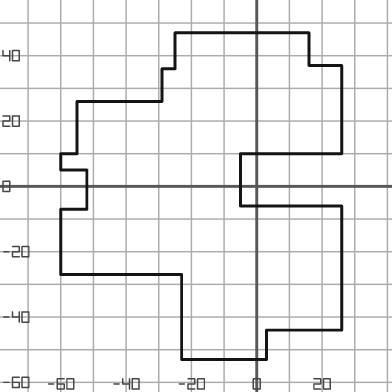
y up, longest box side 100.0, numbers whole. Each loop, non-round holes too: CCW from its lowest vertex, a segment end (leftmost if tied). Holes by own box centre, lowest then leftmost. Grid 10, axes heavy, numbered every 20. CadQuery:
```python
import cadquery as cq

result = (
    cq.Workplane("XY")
    .moveTo(-23.0, -53.0)
    .lineTo(3.0, -53.0)
    .lineTo(3.0, -44.0)
    .lineTo(26.0, -44.0)
    .lineTo(26.0, -6.0)
    .lineTo(-5.0, -6.0)
    .lineTo(-5.0, 10.0)
    .lineTo(26.0, 10.0)
    .lineTo(26.0, 37.0)
    .lineTo(16.0, 37.0)
    .lineTo(16.0, 47.0)
    .lineTo(-25.0, 47.0)
    .lineTo(-25.0, 36.0)
    .lineTo(-29.0, 36.0)
    .lineTo(-29.0, 26.0)
    .lineTo(-55.0, 26.0)
    .lineTo(-55.0, 10.0)
    .lineTo(-60.0, 10.0)
    .lineTo(-60.0, 5.0)
    .lineTo(-52.0, 5.0)
    .lineTo(-52.0, -7.0)
    .lineTo(-60.0, -7.0)
    .lineTo(-60.0, -27.0)
    .lineTo(-23.0, -27.0)
    .close()
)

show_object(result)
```